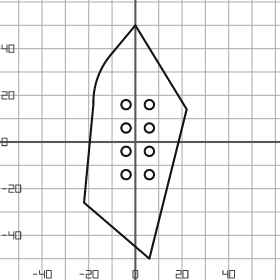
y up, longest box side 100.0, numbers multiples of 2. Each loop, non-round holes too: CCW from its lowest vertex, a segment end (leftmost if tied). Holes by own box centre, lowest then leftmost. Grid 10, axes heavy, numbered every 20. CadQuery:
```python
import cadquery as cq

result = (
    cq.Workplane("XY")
    .moveTo(6.0, -50.0)
    .lineTo(22.0, 14.0)
    .lineTo(0.0, 50.0)
    .lineTo(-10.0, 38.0)
    .threePointArc((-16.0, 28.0), (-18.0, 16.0))
    .lineTo(-22.0, -26.0)
    .close()
    .moveTo(-4.0, -14.0)
    .circle(2.0)
    .moveTo(6.0, -14.0)
    .circle(2.0)
    .moveTo(-4.0, -4.0)
    .circle(2.0)
    .moveTo(6.0, -4.0)
    .circle(2.0)
    .moveTo(-4.0, 6.0)
    .circle(2.0)
    .moveTo(6.0, 6.0)
    .circle(2.0)
    .moveTo(-4.0, 16.0)
    .circle(2.0)
    .moveTo(6.0, 16.0)
    .circle(2.0)
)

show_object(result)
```